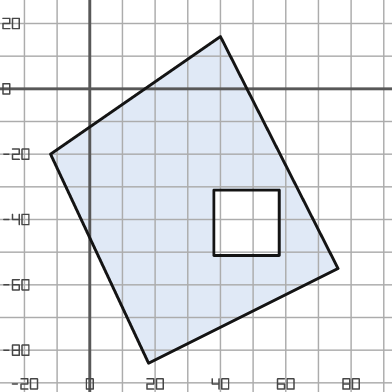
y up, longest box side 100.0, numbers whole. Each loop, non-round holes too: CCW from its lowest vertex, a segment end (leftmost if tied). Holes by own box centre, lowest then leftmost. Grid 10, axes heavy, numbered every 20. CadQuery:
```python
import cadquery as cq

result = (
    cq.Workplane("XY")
    .moveTo(18.0, -84.0)
    .lineTo(76.0, -55.0)
    .lineTo(40.0, 16.0)
    .lineTo(-12.0, -20.0)
    .close()
    .moveTo(38.0, -51.0)
    .lineTo(58.0, -51.0)
    .lineTo(58.0, -31.0)
    .lineTo(38.0, -31.0)
    .close()
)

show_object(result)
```